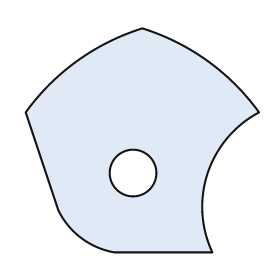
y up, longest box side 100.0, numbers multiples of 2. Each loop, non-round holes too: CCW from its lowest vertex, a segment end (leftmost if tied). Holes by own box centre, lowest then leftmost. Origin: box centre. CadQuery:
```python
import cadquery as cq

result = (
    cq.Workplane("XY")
    .moveTo(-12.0, -48.0)
    .lineTo(30.0, -48.0)
    .threePointArc((28.0, -14.0), (50.0, 12.0))
    .threePointArc((28.0, 34.0), (0.0, 48.0))
    .threePointArc((-28.0, 34.0), (-50.0, 12.0))
    .lineTo(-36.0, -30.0)
    .threePointArc((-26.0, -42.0), (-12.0, -48.0))
    .close()
    .moveTo(-4.0, -14.0)
    .circle(10.0)
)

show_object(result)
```